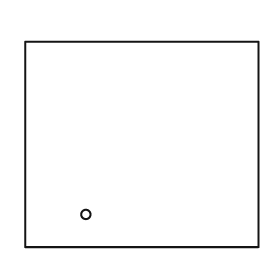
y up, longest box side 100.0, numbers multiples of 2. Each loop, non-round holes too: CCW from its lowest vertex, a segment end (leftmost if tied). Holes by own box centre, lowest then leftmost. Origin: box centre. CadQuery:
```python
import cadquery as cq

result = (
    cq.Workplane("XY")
    .moveTo(-50.0, -44.0)
    .lineTo(50.0, -44.0)
    .lineTo(50.0, 44.0)
    .lineTo(-50.0, 44.0)
    .close()
    .moveTo(-24.0, -30.0)
    .circle(2.0)
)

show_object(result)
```